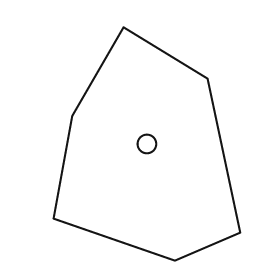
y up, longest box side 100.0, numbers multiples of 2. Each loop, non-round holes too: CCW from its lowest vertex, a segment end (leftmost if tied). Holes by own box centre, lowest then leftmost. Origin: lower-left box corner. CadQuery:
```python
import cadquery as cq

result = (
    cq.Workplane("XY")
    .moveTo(52.0, 0.0)
    .lineTo(80.0, 12.0)
    .lineTo(66.0, 78.0)
    .lineTo(30.0, 100.0)
    .lineTo(8.0, 62.0)
    .lineTo(0.0, 18.0)
    .close()
    .moveTo(40.0, 50.0)
    .circle(4.0)
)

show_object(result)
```